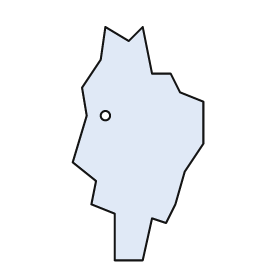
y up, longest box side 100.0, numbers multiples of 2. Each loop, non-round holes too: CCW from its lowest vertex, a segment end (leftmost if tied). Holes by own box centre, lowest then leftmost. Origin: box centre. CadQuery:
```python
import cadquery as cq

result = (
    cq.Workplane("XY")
    .moveTo(-10.0, -50.0)
    .lineTo(2.0, -50.0)
    .lineTo(6.0, -32.0)
    .lineTo(12.0, -34.0)
    .lineTo(16.0, -26.0)
    .lineTo(20.0, -12.0)
    .lineTo(28.0, 0.0)
    .lineTo(28.0, 18.0)
    .lineTo(18.0, 22.0)
    .lineTo(14.0, 30.0)
    .lineTo(6.0, 30.0)
    .lineTo(2.0, 50.0)
    .lineTo(-4.0, 44.0)
    .lineTo(-14.0, 50.0)
    .lineTo(-16.0, 36.0)
    .lineTo(-24.0, 24.0)
    .lineTo(-22.0, 12.0)
    .lineTo(-28.0, -8.0)
    .lineTo(-18.0, -16.0)
    .lineTo(-20.0, -26.0)
    .lineTo(-10.0, -30.0)
    .close()
    .moveTo(-14.0, 12.0)
    .circle(2.0)
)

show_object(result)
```